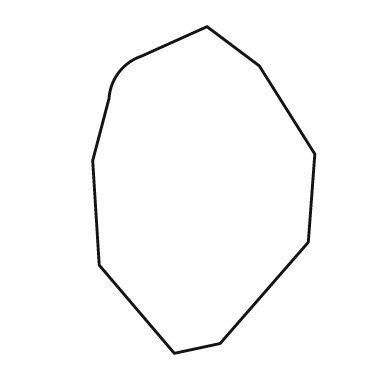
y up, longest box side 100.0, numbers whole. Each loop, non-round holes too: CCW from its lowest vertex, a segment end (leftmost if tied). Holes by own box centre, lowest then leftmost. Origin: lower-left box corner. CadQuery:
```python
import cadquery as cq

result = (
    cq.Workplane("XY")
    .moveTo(25.0, 0.0)
    .lineTo(39.0, 3.0)
    .lineTo(66.0, 34.0)
    .lineTo(68.0, 61.0)
    .lineTo(51.0, 88.0)
    .lineTo(35.0, 100.0)
    .lineTo(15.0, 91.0)
    .threePointArc((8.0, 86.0), (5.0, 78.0))
    .lineTo(0.0, 59.0)
    .lineTo(2.0, 27.0)
    .close()
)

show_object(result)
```